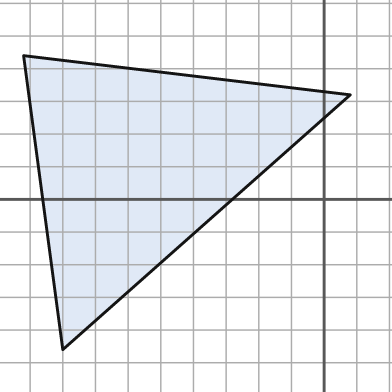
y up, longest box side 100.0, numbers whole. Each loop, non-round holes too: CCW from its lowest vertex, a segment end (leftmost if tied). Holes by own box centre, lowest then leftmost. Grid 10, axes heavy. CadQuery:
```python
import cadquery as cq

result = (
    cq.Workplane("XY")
    .moveTo(-80.0, -46.0)
    .lineTo(8.0, 32.0)
    .lineTo(-92.0, 44.0)
    .close()
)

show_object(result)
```